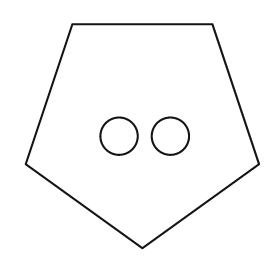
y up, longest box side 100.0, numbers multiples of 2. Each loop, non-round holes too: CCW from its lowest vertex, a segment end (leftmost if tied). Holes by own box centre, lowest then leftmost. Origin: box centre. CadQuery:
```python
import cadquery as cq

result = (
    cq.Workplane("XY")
    .moveTo(0.0, -48.0)
    .lineTo(50.0, -12.0)
    .lineTo(30.0, 48.0)
    .lineTo(-30.0, 48.0)
    .lineTo(-50.0, -12.0)
    .close()
    .moveTo(-10.0, 0.0)
    .circle(8.0)
    .moveTo(12.0, 0.0)
    .circle(8.0)
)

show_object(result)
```